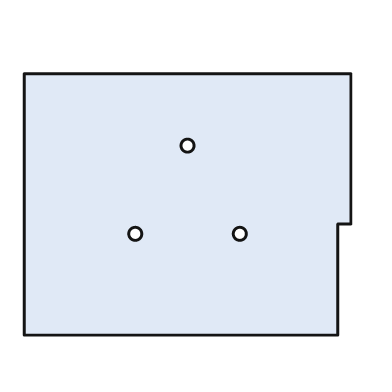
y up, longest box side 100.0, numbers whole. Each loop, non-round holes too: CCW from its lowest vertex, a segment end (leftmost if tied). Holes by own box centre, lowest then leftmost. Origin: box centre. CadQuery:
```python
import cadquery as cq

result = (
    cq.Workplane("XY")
    .moveTo(-50.0, -40.0)
    .lineTo(46.0, -40.0)
    .lineTo(46.0, -6.0)
    .lineTo(50.0, -6.0)
    .lineTo(50.0, 40.0)
    .lineTo(-50.0, 40.0)
    .close()
    .moveTo(-16.0, -9.0)
    .circle(2.0)
    .moveTo(16.0, -9.0)
    .circle(2.0)
    .moveTo(0.0, 18.0)
    .circle(2.0)
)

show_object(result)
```